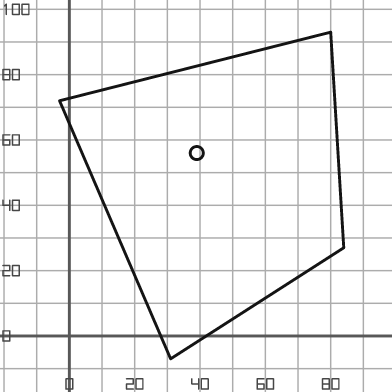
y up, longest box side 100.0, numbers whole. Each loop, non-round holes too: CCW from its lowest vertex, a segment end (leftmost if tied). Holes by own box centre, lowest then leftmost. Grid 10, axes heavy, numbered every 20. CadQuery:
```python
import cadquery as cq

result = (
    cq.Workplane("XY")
    .moveTo(31.0, -7.0)
    .lineTo(84.0, 27.0)
    .lineTo(80.0, 93.0)
    .lineTo(-3.0, 72.0)
    .close()
    .moveTo(39.0, 56.0)
    .circle(2.0)
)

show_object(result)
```